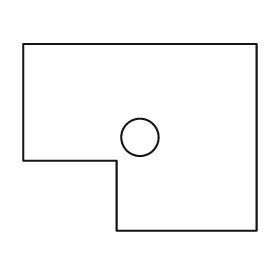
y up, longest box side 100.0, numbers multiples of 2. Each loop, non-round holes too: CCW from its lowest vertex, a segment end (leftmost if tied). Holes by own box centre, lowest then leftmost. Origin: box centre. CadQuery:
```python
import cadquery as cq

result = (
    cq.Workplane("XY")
    .moveTo(-10.0, -40.0)
    .lineTo(50.0, -40.0)
    .lineTo(50.0, 40.0)
    .lineTo(-50.0, 40.0)
    .lineTo(-50.0, -10.0)
    .lineTo(-10.0, -10.0)
    .close()
    .moveTo(0.0, 0.0)
    .circle(8.0)
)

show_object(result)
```